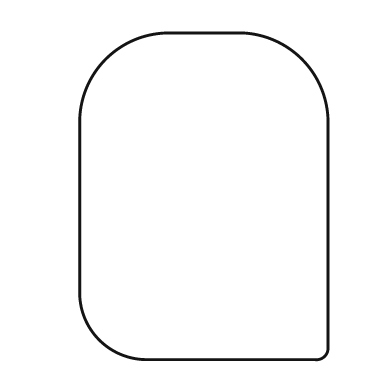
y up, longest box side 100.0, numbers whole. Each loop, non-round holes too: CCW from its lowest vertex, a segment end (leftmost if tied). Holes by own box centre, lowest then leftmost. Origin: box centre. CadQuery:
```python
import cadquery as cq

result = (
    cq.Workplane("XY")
    .moveTo(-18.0, -50.0)
    .lineTo(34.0, -50.0)
    .threePointArc((37.0, -49.0), (38.0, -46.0))
    .lineTo(38.0, 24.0)
    .threePointArc((30.0, 42.0), (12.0, 50.0))
    .lineTo(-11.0, 50.0)
    .threePointArc((-30.0, 42.0), (-38.0, 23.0))
    .lineTo(-38.0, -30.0)
    .threePointArc((-32.0, -44.0), (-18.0, -50.0))
    .close()
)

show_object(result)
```